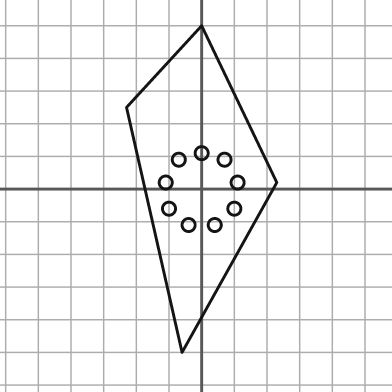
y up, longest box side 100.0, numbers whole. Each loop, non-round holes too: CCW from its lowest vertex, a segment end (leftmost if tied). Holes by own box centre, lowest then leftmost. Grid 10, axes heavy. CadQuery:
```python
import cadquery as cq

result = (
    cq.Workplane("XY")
    .moveTo(-6.0, -50.0)
    .lineTo(23.0, 2.0)
    .lineTo(0.0, 50.0)
    .lineTo(-23.0, 25.0)
    .close()
    .moveTo(-4.0, -11.0)
    .circle(2.0)
    .moveTo(4.0, -11.0)
    .circle(2.0)
    .moveTo(-10.0, -6.0)
    .circle(2.0)
    .moveTo(10.0, -6.0)
    .circle(2.0)
    .moveTo(-11.0, 2.0)
    .circle(2.0)
    .moveTo(11.0, 2.0)
    .circle(2.0)
    .moveTo(-7.0, 9.0)
    .circle(2.0)
    .moveTo(7.0, 9.0)
    .circle(2.0)
    .moveTo(0.0, 11.0)
    .circle(2.0)
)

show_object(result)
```